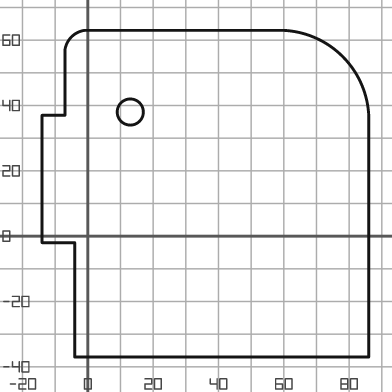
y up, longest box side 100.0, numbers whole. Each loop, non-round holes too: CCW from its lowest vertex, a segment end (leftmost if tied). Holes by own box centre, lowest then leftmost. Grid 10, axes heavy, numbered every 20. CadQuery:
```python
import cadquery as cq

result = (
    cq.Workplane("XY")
    .moveTo(-4.0, -37.0)
    .lineTo(86.0, -37.0)
    .lineTo(86.0, 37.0)
    .threePointArc((78.0, 55.0), (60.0, 63.0))
    .lineTo(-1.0, 63.0)
    .threePointArc((-5.0, 61.0), (-7.0, 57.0))
    .lineTo(-7.0, 37.0)
    .lineTo(-14.0, 37.0)
    .lineTo(-14.0, -2.0)
    .lineTo(-4.0, -2.0)
    .close()
    .moveTo(13.0, 38.0)
    .circle(4.0)
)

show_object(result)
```